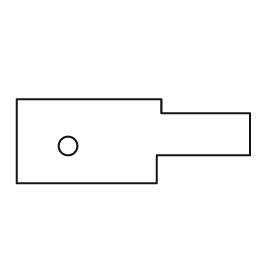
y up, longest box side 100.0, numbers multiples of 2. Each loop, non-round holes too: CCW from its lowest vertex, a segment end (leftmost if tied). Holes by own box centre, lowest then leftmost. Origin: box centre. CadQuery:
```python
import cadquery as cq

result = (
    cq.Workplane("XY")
    .moveTo(-50.0, -18.0)
    .lineTo(10.0, -18.0)
    .lineTo(10.0, -6.0)
    .lineTo(50.0, -6.0)
    .lineTo(50.0, 12.0)
    .lineTo(12.0, 12.0)
    .lineTo(12.0, 18.0)
    .lineTo(-50.0, 18.0)
    .close()
    .moveTo(-28.0, -2.0)
    .circle(4.0)
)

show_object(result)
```